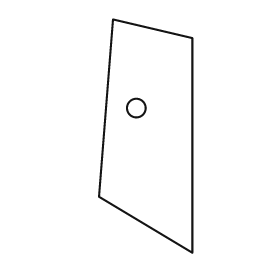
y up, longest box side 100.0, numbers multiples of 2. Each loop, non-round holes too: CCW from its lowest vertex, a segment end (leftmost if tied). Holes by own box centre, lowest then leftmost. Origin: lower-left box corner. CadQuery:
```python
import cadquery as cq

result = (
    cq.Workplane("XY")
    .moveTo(40.0, 0.0)
    .lineTo(40.0, 92.0)
    .lineTo(6.0, 100.0)
    .lineTo(0.0, 24.0)
    .close()
    .moveTo(16.0, 62.0)
    .circle(4.0)
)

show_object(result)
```